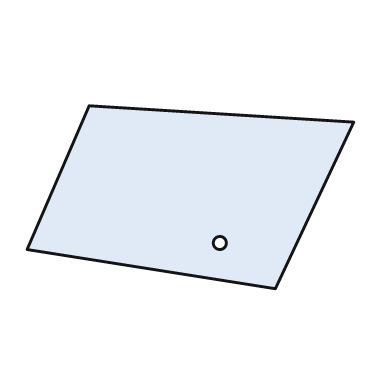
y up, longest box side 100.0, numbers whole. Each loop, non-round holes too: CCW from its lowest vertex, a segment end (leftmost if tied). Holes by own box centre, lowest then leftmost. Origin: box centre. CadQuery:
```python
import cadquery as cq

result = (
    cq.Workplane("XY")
    .moveTo(26.0, -28.0)
    .lineTo(50.0, 23.0)
    .lineTo(-31.0, 28.0)
    .lineTo(-50.0, -16.0)
    .close()
    .moveTo(9.0, -14.0)
    .circle(2.0)
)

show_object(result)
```